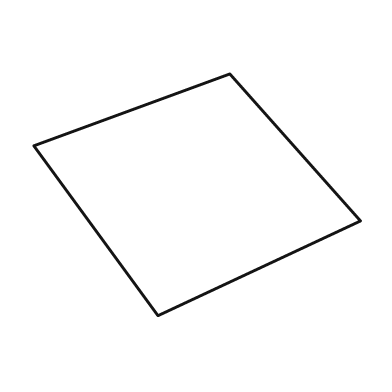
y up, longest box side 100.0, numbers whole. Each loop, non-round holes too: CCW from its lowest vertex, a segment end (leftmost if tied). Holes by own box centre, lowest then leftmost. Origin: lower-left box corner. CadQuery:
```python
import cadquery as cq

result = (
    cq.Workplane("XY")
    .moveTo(38.0, 0.0)
    .lineTo(100.0, 29.0)
    .lineTo(60.0, 74.0)
    .lineTo(0.0, 52.0)
    .close()
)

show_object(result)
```